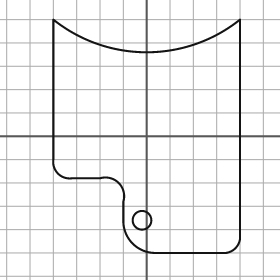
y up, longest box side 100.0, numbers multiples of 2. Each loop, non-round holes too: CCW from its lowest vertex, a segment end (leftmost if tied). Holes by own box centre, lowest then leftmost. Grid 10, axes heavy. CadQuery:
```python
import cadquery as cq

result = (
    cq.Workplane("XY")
    .moveTo(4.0, -50.0)
    .lineTo(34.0, -50.0)
    .threePointArc((38.0, -48.0), (40.0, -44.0))
    .lineTo(40.0, 50.0)
    .threePointArc((0.0, 36.0), (-40.0, 50.0))
    .lineTo(-40.0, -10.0)
    .threePointArc((-38.0, -16.0), (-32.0, -18.0))
    .lineTo(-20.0, -18.0)
    .threePointArc((-12.0, -20.0), (-10.0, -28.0))
    .lineTo(-10.0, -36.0)
    .threePointArc((-6.0, -46.0), (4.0, -50.0))
    .close()
    .moveTo(-2.0, -36.0)
    .circle(4.0)
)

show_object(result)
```